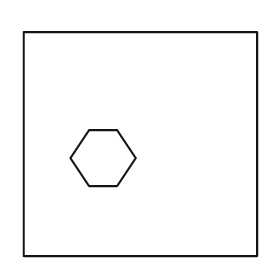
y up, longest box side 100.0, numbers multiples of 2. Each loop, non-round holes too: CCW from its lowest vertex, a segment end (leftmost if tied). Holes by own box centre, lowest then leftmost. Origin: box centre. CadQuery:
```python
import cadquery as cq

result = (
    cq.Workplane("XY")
    .moveTo(-50.0, -48.0)
    .lineTo(50.0, -48.0)
    .lineTo(50.0, 48.0)
    .lineTo(-50.0, 48.0)
    .close()
    .moveTo(-22.0, -18.0)
    .lineTo(-10.0, -18.0)
    .lineTo(-2.0, -6.0)
    .lineTo(-10.0, 6.0)
    .lineTo(-22.0, 6.0)
    .lineTo(-30.0, -6.0)
    .close()
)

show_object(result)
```